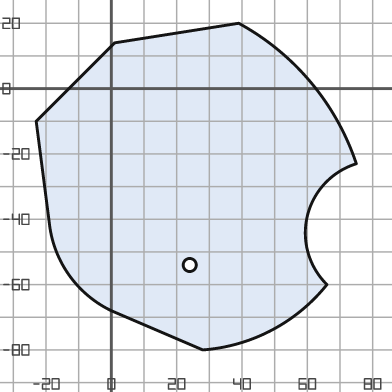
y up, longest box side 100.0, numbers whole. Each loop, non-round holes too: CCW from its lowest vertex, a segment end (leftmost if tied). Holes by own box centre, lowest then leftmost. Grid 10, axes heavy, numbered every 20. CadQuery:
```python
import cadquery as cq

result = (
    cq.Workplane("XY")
    .moveTo(28.0, -80.0)
    .threePointArc((49.0, -74.0), (66.0, -60.0))
    .threePointArc((60.0, -39.0), (75.0, -23.0))
    .threePointArc((61.0, 2.0), (39.0, 20.0))
    .lineTo(1.0, 14.0)
    .lineTo(-23.0, -10.0)
    .lineTo(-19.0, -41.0)
    .threePointArc((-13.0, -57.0), (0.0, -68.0))
    .close()
    .moveTo(24.0, -54.0)
    .circle(2.0)
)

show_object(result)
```